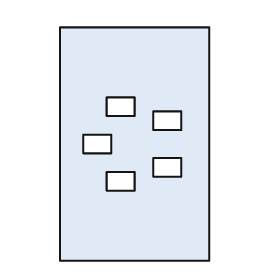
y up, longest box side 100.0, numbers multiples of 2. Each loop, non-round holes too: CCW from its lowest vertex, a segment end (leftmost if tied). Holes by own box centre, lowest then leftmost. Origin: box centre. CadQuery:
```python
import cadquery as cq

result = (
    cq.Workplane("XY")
    .moveTo(-32.0, -50.0)
    .lineTo(32.0, -50.0)
    .lineTo(32.0, 50.0)
    .lineTo(-32.0, 50.0)
    .close()
    .moveTo(-12.0, -20.0)
    .lineTo(0.0, -20.0)
    .lineTo(0.0, -12.0)
    .lineTo(-12.0, -12.0)
    .close()
    .moveTo(8.0, -14.0)
    .lineTo(20.0, -14.0)
    .lineTo(20.0, -6.0)
    .lineTo(8.0, -6.0)
    .close()
    .moveTo(-22.0, -4.0)
    .lineTo(-10.0, -4.0)
    .lineTo(-10.0, 4.0)
    .lineTo(-22.0, 4.0)
    .close()
    .moveTo(8.0, 6.0)
    .lineTo(20.0, 6.0)
    .lineTo(20.0, 14.0)
    .lineTo(8.0, 14.0)
    .close()
    .moveTo(-12.0, 12.0)
    .lineTo(0.0, 12.0)
    .lineTo(0.0, 20.0)
    .lineTo(-12.0, 20.0)
    .close()
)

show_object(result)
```